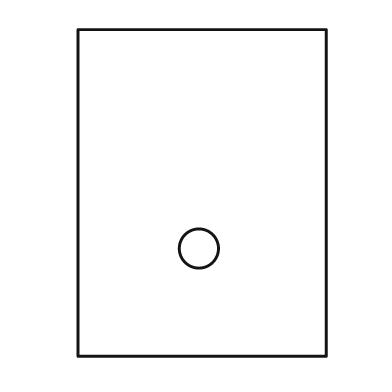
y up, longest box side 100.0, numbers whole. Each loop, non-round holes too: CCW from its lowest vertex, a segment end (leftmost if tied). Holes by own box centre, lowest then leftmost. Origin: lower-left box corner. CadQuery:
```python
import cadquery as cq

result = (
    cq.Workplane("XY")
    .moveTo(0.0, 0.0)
    .lineTo(76.0, 0.0)
    .lineTo(76.0, 100.0)
    .lineTo(0.0, 100.0)
    .close()
    .moveTo(37.0, 33.0)
    .circle(6.0)
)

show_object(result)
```